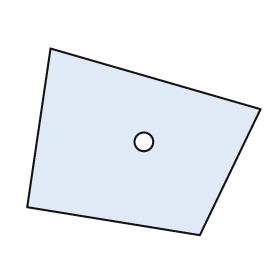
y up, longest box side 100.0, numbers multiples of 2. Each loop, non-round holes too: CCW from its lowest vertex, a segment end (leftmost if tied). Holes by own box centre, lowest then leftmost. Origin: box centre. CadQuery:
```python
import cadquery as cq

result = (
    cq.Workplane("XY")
    .moveTo(24.0, -40.0)
    .lineTo(50.0, 14.0)
    .lineTo(-40.0, 40.0)
    .lineTo(-50.0, -28.0)
    .close()
    .moveTo(0.0, 0.0)
    .circle(4.0)
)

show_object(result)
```